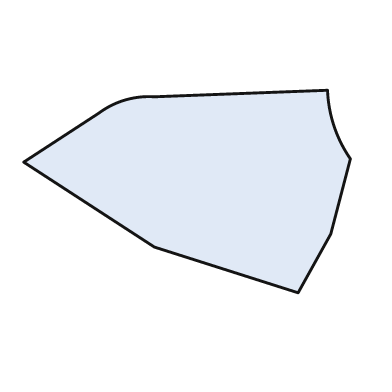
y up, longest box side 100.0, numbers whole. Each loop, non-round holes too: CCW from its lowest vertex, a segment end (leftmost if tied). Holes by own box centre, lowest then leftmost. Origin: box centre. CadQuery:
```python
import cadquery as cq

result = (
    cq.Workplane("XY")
    .moveTo(34.0, -31.0)
    .lineTo(44.0, -13.0)
    .lineTo(50.0, 10.0)
    .threePointArc((45.0, 20.0), (43.0, 31.0))
    .lineTo(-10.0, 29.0)
    .threePointArc((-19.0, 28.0), (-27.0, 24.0))
    .lineTo(-50.0, 9.0)
    .lineTo(-10.0, -17.0)
    .close()
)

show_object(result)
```